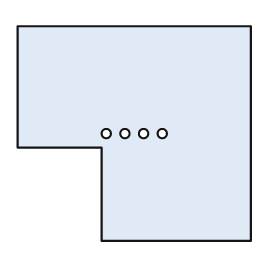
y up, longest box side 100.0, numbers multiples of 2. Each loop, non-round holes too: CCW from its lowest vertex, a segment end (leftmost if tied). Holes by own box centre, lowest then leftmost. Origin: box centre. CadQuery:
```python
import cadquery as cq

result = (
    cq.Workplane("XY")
    .moveTo(-14.0, -46.0)
    .lineTo(50.0, -46.0)
    .lineTo(50.0, 46.0)
    .lineTo(-50.0, 46.0)
    .lineTo(-50.0, -6.0)
    .lineTo(-14.0, -6.0)
    .close()
    .moveTo(-12.0, 0.0)
    .circle(2.0)
    .moveTo(-4.0, 0.0)
    .circle(2.0)
    .moveTo(4.0, 0.0)
    .circle(2.0)
    .moveTo(12.0, 0.0)
    .circle(2.0)
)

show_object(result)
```